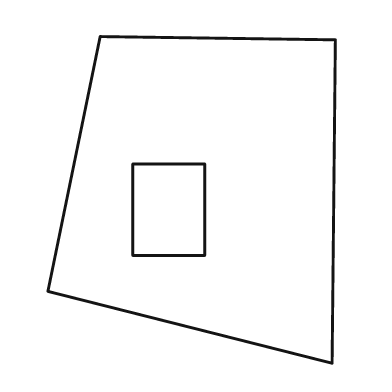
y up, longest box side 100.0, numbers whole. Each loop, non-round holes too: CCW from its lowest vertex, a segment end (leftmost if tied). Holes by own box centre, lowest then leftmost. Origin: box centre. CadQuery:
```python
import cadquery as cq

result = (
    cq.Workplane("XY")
    .moveTo(43.0, -50.0)
    .lineTo(44.0, 49.0)
    .lineTo(-28.0, 50.0)
    .lineTo(-44.0, -28.0)
    .close()
    .moveTo(-18.0, -17.0)
    .lineTo(4.0, -17.0)
    .lineTo(4.0, 11.0)
    .lineTo(-18.0, 11.0)
    .close()
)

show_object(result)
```